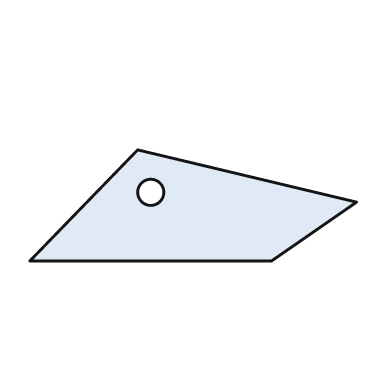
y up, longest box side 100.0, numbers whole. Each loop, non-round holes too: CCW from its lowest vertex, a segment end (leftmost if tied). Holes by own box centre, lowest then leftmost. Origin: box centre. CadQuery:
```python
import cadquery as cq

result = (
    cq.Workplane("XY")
    .moveTo(-50.0, -17.0)
    .lineTo(24.0, -17.0)
    .lineTo(50.0, 1.0)
    .lineTo(-17.0, 17.0)
    .close()
    .moveTo(-13.0, 4.0)
    .circle(4.0)
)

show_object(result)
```